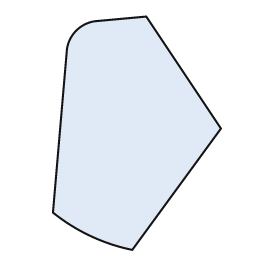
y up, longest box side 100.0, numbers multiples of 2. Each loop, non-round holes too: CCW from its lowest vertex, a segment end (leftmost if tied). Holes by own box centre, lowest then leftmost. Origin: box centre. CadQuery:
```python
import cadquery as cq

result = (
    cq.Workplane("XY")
    .moveTo(-2.0, -50.0)
    .lineTo(36.0, 2.0)
    .lineTo(4.0, 50.0)
    .lineTo(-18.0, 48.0)
    .threePointArc((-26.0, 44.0), (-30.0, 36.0))
    .lineTo(-36.0, -34.0)
    .threePointArc((-20.0, -44.0), (-2.0, -50.0))
    .close()
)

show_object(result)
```